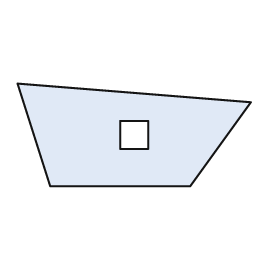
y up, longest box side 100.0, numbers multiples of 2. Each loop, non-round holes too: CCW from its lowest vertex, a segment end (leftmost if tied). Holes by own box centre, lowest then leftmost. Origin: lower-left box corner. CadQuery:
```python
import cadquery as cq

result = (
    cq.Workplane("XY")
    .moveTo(14.0, 0.0)
    .lineTo(74.0, 0.0)
    .lineTo(100.0, 36.0)
    .lineTo(0.0, 44.0)
    .close()
    .moveTo(44.0, 16.0)
    .lineTo(56.0, 16.0)
    .lineTo(56.0, 28.0)
    .lineTo(44.0, 28.0)
    .close()
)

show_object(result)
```